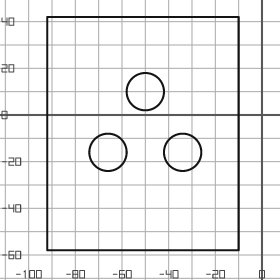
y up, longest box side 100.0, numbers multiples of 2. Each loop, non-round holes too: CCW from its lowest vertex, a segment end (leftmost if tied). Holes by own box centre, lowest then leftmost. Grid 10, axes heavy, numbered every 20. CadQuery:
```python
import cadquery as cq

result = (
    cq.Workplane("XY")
    .moveTo(-92.0, -58.0)
    .lineTo(-10.0, -58.0)
    .lineTo(-10.0, 42.0)
    .lineTo(-92.0, 42.0)
    .close()
    .moveTo(-66.0, -16.0)
    .circle(8.0)
    .moveTo(-34.0, -16.0)
    .circle(8.0)
    .moveTo(-50.0, 10.0)
    .circle(8.0)
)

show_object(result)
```